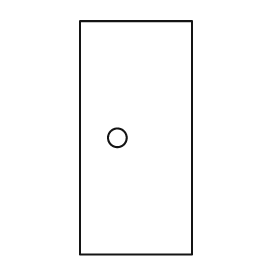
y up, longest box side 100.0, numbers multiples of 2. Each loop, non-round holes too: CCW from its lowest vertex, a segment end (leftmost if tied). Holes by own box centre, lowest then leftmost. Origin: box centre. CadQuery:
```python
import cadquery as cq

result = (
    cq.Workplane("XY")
    .moveTo(-24.0, -50.0)
    .lineTo(24.0, -50.0)
    .lineTo(24.0, 50.0)
    .lineTo(-24.0, 50.0)
    .close()
    .moveTo(-8.0, 0.0)
    .circle(4.0)
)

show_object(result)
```